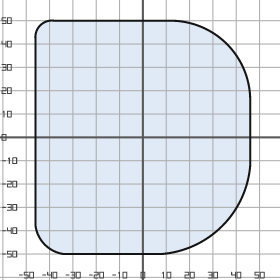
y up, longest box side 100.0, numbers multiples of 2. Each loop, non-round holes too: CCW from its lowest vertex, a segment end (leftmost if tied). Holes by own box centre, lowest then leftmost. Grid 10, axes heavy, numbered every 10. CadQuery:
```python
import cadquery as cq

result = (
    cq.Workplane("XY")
    .moveTo(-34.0, -50.0)
    .lineTo(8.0, -50.0)
    .threePointArc((34.0, -38.0), (46.0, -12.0))
    .lineTo(46.0, 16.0)
    .threePointArc((36.0, 40.0), (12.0, 50.0))
    .lineTo(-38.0, 50.0)
    .threePointArc((-44.0, 48.0), (-46.0, 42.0))
    .lineTo(-46.0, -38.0)
    .threePointArc((-42.0, -46.0), (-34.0, -50.0))
    .close()
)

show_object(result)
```